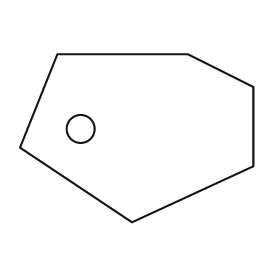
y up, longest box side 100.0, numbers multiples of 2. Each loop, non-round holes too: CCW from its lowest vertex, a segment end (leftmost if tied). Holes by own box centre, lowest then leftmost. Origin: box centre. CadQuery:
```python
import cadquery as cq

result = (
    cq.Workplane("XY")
    .moveTo(-2.0, -36.0)
    .lineTo(50.0, -12.0)
    .lineTo(50.0, 22.0)
    .lineTo(22.0, 36.0)
    .lineTo(-34.0, 36.0)
    .lineTo(-50.0, -4.0)
    .close()
    .moveTo(-24.0, 4.0)
    .circle(6.0)
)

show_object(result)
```